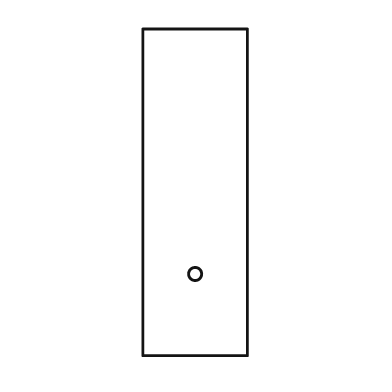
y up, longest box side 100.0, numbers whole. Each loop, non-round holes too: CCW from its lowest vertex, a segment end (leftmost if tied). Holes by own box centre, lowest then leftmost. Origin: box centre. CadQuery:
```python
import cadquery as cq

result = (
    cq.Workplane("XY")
    .moveTo(-16.0, -50.0)
    .lineTo(16.0, -50.0)
    .lineTo(16.0, 50.0)
    .lineTo(-16.0, 50.0)
    .close()
    .moveTo(0.0, -25.0)
    .circle(2.0)
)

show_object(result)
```